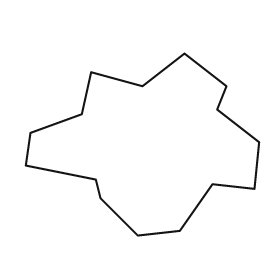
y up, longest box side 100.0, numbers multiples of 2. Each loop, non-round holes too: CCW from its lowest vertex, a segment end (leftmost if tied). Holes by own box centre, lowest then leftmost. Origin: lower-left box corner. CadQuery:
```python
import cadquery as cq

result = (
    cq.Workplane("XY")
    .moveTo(48.0, 0.0)
    .lineTo(66.0, 2.0)
    .lineTo(80.0, 22.0)
    .lineTo(98.0, 20.0)
    .lineTo(100.0, 40.0)
    .lineTo(82.0, 54.0)
    .lineTo(86.0, 64.0)
    .lineTo(68.0, 78.0)
    .lineTo(50.0, 64.0)
    .lineTo(28.0, 70.0)
    .lineTo(24.0, 52.0)
    .lineTo(2.0, 44.0)
    .lineTo(0.0, 30.0)
    .lineTo(30.0, 24.0)
    .lineTo(32.0, 16.0)
    .close()
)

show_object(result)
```